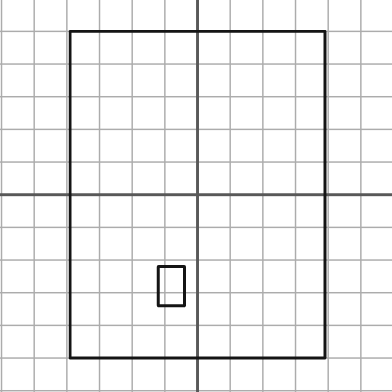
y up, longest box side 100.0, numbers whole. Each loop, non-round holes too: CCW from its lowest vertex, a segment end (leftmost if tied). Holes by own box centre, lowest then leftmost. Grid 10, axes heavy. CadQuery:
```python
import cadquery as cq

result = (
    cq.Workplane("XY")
    .moveTo(-39.0, -50.0)
    .lineTo(39.0, -50.0)
    .lineTo(39.0, 50.0)
    .lineTo(-39.0, 50.0)
    .close()
    .moveTo(-12.0, -34.0)
    .lineTo(-4.0, -34.0)
    .lineTo(-4.0, -22.0)
    .lineTo(-12.0, -22.0)
    .close()
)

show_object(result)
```